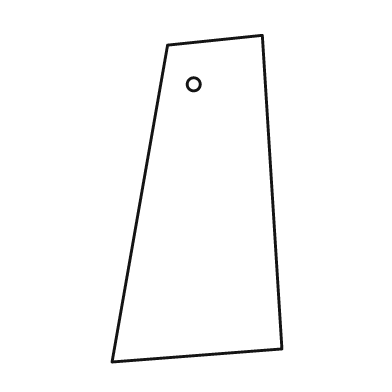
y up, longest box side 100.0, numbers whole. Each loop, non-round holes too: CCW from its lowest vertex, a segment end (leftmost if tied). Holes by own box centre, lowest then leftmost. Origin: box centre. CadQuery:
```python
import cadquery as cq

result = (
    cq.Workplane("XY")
    .moveTo(-26.0, -50.0)
    .lineTo(26.0, -46.0)
    .lineTo(20.0, 50.0)
    .lineTo(-9.0, 47.0)
    .close()
    .moveTo(-1.0, 35.0)
    .circle(2.0)
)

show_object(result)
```